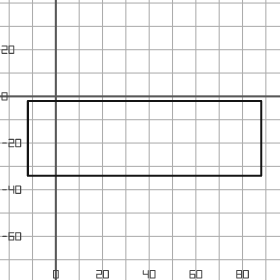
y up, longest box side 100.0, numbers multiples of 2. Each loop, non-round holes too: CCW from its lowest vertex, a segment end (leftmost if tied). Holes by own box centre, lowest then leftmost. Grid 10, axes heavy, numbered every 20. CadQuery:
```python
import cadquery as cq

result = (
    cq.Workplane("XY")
    .moveTo(-12.0, -34.0)
    .lineTo(88.0, -34.0)
    .lineTo(88.0, -2.0)
    .lineTo(-12.0, -2.0)
    .close()
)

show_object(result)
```